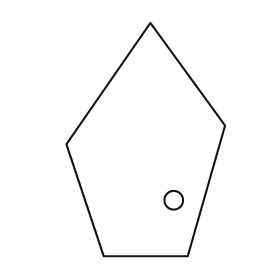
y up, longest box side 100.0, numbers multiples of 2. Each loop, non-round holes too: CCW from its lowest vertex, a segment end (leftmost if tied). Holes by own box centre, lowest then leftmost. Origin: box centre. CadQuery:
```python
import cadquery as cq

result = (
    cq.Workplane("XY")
    .moveTo(-18.0, -50.0)
    .lineTo(18.0, -50.0)
    .lineTo(34.0, 6.0)
    .lineTo(2.0, 50.0)
    .lineTo(-34.0, -2.0)
    .close()
    .moveTo(12.0, -26.0)
    .circle(4.0)
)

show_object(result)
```